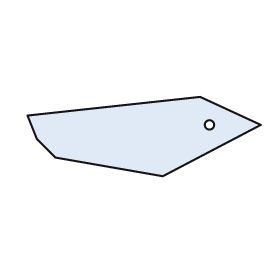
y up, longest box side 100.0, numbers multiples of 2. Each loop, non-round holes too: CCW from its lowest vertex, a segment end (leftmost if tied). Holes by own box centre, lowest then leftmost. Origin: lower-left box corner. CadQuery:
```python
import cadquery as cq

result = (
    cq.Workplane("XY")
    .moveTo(58.0, 0.0)
    .lineTo(100.0, 22.0)
    .lineTo(74.0, 34.0)
    .lineTo(0.0, 26.0)
    .lineTo(4.0, 16.0)
    .lineTo(12.0, 8.0)
    .close()
    .moveTo(78.0, 22.0)
    .circle(2.0)
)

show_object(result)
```